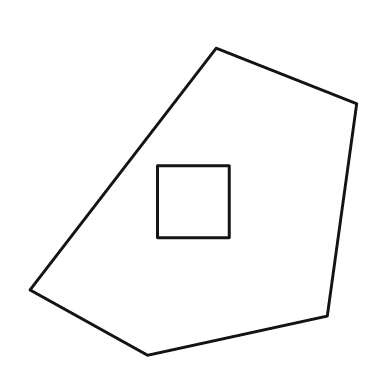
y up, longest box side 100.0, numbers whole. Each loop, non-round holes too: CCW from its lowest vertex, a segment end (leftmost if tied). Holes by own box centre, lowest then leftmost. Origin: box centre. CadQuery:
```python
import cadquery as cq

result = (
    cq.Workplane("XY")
    .moveTo(-14.0, -47.0)
    .lineTo(41.0, -35.0)
    .lineTo(50.0, 30.0)
    .lineTo(7.0, 47.0)
    .lineTo(-50.0, -27.0)
    .close()
    .moveTo(-11.0, -11.0)
    .lineTo(11.0, -11.0)
    .lineTo(11.0, 11.0)
    .lineTo(-11.0, 11.0)
    .close()
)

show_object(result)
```